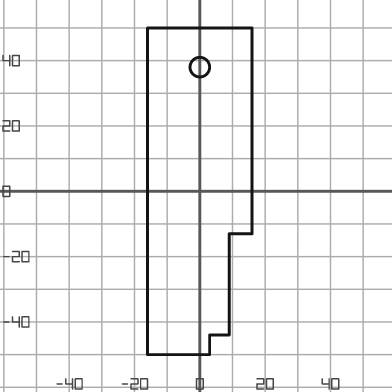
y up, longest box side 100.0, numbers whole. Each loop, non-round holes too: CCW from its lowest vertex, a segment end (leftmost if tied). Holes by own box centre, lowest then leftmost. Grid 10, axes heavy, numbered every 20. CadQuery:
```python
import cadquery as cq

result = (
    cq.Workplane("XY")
    .moveTo(-16.0, -50.0)
    .lineTo(3.0, -50.0)
    .lineTo(3.0, -44.0)
    .lineTo(9.0, -44.0)
    .lineTo(9.0, -13.0)
    .lineTo(16.0, -13.0)
    .lineTo(16.0, 50.0)
    .lineTo(-16.0, 50.0)
    .close()
    .moveTo(0.0, 38.0)
    .circle(3.0)
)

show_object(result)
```